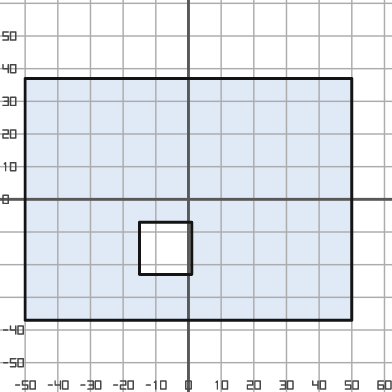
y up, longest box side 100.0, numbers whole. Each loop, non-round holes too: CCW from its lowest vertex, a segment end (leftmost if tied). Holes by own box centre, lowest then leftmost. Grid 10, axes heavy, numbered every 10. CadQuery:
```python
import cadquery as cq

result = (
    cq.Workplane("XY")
    .moveTo(-50.0, -37.0)
    .lineTo(50.0, -37.0)
    .lineTo(50.0, 37.0)
    .lineTo(-50.0, 37.0)
    .close()
    .moveTo(-15.0, -23.0)
    .lineTo(1.0, -23.0)
    .lineTo(1.0, -7.0)
    .lineTo(-15.0, -7.0)
    .close()
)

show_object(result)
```